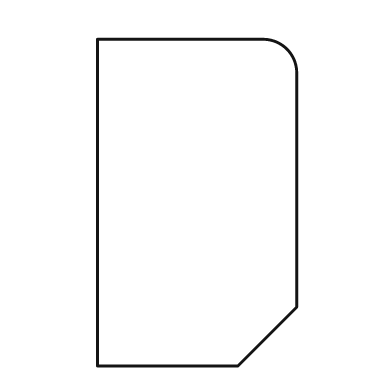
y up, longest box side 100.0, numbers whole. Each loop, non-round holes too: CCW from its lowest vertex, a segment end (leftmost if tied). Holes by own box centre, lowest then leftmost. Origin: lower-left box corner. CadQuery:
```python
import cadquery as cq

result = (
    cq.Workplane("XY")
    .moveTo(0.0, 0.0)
    .lineTo(43.0, 0.0)
    .lineTo(61.0, 18.0)
    .lineTo(61.0, 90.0)
    .threePointArc((58.0, 97.0), (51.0, 100.0))
    .lineTo(0.0, 100.0)
    .close()
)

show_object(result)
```